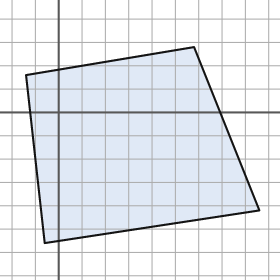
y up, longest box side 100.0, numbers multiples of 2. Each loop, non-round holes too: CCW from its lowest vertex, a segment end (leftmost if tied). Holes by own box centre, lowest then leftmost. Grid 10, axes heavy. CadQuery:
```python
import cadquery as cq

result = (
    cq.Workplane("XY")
    .moveTo(-6.0, -56.0)
    .lineTo(86.0, -42.0)
    .lineTo(58.0, 28.0)
    .lineTo(-14.0, 16.0)
    .close()
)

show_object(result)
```